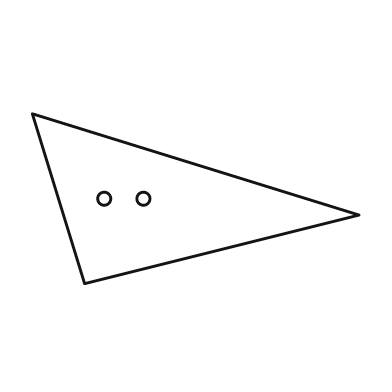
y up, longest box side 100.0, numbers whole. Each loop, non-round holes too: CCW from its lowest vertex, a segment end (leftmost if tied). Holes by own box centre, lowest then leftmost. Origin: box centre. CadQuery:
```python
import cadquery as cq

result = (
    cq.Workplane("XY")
    .moveTo(-34.0, -26.0)
    .lineTo(50.0, -5.0)
    .lineTo(-50.0, 26.0)
    .close()
    .moveTo(-28.0, 0.0)
    .circle(2.0)
    .moveTo(-16.0, 0.0)
    .circle(2.0)
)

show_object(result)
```